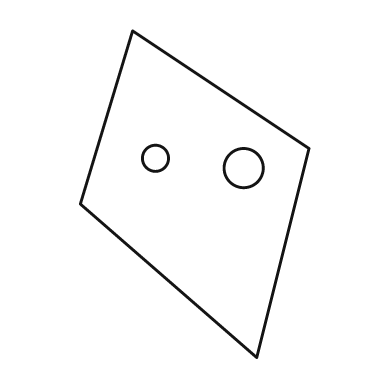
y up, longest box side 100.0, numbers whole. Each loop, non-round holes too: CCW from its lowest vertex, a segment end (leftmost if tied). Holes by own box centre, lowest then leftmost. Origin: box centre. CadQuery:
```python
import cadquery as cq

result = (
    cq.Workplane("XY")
    .moveTo(19.0, -50.0)
    .lineTo(35.0, 14.0)
    .lineTo(-19.0, 50.0)
    .lineTo(-35.0, -3.0)
    .close()
    .moveTo(15.0, 8.0)
    .circle(6.0)
    .moveTo(-12.0, 11.0)
    .circle(4.0)
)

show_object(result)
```